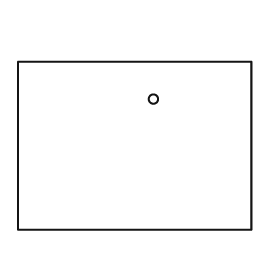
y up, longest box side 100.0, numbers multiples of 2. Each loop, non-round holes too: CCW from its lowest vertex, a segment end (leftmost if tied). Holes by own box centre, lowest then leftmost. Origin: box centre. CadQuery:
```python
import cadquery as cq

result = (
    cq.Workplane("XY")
    .moveTo(-50.0, -36.0)
    .lineTo(50.0, -36.0)
    .lineTo(50.0, 36.0)
    .lineTo(-50.0, 36.0)
    .close()
    .moveTo(8.0, 20.0)
    .circle(2.0)
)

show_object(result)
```